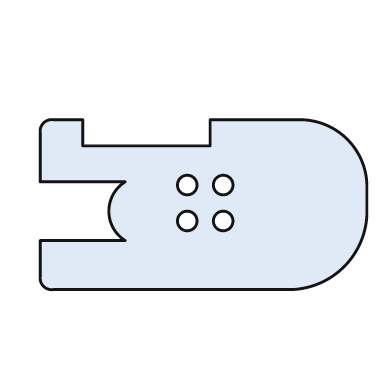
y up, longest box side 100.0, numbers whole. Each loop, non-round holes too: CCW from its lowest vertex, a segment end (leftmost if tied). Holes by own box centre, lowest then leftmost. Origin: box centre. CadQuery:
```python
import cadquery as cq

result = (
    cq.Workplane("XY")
    .moveTo(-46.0, -26.0)
    .lineTo(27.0, -26.0)
    .threePointArc((43.0, -19.0), (50.0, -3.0))
    .lineTo(50.0, 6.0)
    .threePointArc((44.0, 20.0), (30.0, 26.0))
    .lineTo(2.0, 26.0)
    .lineTo(2.0, 18.0)
    .lineTo(-37.0, 18.0)
    .lineTo(-37.0, 26.0)
    .lineTo(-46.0, 26.0)
    .threePointArc((-49.0, 25.0), (-50.0, 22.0))
    .lineTo(-50.0, 7.0)
    .lineTo(-24.0, 7.0)
    .threePointArc((-29.0, -2.0), (-24.0, -11.0))
    .lineTo(-50.0, -11.0)
    .lineTo(-50.0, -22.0)
    .threePointArc((-49.0, -25.0), (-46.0, -26.0))
    .close()
    .moveTo(-5.0, -5.0)
    .circle(3.0)
    .moveTo(6.0, -5.0)
    .circle(3.0)
    .moveTo(-5.0, 6.0)
    .circle(3.0)
    .moveTo(6.0, 6.0)
    .circle(3.0)
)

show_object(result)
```